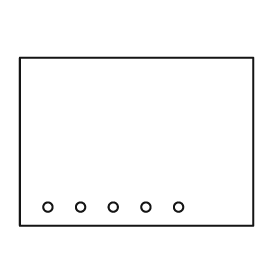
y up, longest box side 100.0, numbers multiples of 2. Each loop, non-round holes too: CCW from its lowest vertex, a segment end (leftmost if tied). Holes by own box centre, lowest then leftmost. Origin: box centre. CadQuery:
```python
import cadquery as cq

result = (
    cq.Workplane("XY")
    .moveTo(-50.0, -36.0)
    .lineTo(50.0, -36.0)
    .lineTo(50.0, 36.0)
    .lineTo(-50.0, 36.0)
    .close()
    .moveTo(-38.0, -28.0)
    .circle(2.0)
    .moveTo(-24.0, -28.0)
    .circle(2.0)
    .moveTo(-10.0, -28.0)
    .circle(2.0)
    .moveTo(4.0, -28.0)
    .circle(2.0)
    .moveTo(18.0, -28.0)
    .circle(2.0)
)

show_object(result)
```